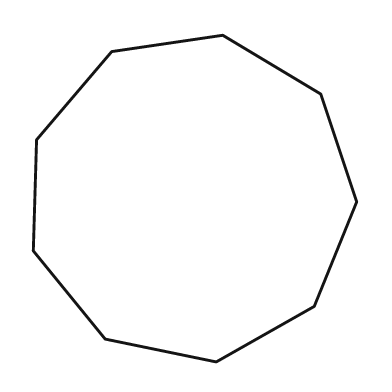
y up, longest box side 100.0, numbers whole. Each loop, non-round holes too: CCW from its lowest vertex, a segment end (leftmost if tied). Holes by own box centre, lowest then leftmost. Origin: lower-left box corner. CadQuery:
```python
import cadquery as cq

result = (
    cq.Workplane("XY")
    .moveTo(56.0, 0.0)
    .lineTo(86.0, 17.0)
    .lineTo(99.0, 49.0)
    .lineTo(88.0, 82.0)
    .lineTo(58.0, 100.0)
    .lineTo(24.0, 95.0)
    .lineTo(1.0, 68.0)
    .lineTo(0.0, 34.0)
    .lineTo(22.0, 7.0)
    .close()
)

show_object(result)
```